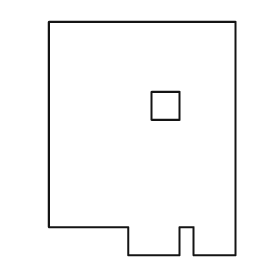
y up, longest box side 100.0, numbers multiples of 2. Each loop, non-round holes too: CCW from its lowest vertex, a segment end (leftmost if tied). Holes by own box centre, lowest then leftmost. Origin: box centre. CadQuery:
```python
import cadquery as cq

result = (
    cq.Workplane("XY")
    .moveTo(-6.0, -50.0)
    .lineTo(16.0, -50.0)
    .lineTo(16.0, -38.0)
    .lineTo(22.0, -38.0)
    .lineTo(22.0, -50.0)
    .lineTo(40.0, -50.0)
    .lineTo(40.0, 50.0)
    .lineTo(-40.0, 50.0)
    .lineTo(-40.0, -38.0)
    .lineTo(-6.0, -38.0)
    .close()
    .moveTo(4.0, 8.0)
    .lineTo(16.0, 8.0)
    .lineTo(16.0, 20.0)
    .lineTo(4.0, 20.0)
    .close()
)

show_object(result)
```